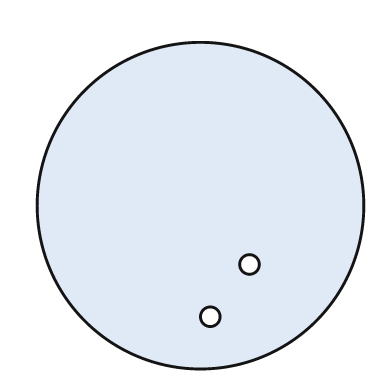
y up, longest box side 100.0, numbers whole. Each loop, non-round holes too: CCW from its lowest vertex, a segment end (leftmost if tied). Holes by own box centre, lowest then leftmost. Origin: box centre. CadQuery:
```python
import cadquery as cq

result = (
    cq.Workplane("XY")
    .moveTo(0.0, 0.0)
    .circle(50.0)
    .moveTo(3.0, -34.0)
    .circle(3.0)
    .moveTo(15.0, -18.0)
    .circle(3.0)
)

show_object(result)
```